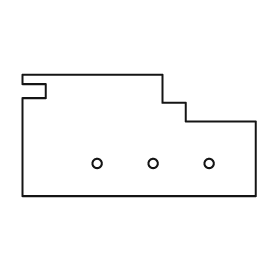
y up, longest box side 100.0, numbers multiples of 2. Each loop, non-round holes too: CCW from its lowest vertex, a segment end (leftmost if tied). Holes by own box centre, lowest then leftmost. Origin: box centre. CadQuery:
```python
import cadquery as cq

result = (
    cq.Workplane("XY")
    .moveTo(-50.0, -26.0)
    .lineTo(50.0, -26.0)
    .lineTo(50.0, 6.0)
    .lineTo(20.0, 6.0)
    .lineTo(20.0, 14.0)
    .lineTo(10.0, 14.0)
    .lineTo(10.0, 26.0)
    .lineTo(-50.0, 26.0)
    .lineTo(-50.0, 22.0)
    .lineTo(-40.0, 22.0)
    .lineTo(-40.0, 16.0)
    .lineTo(-50.0, 16.0)
    .close()
    .moveTo(-18.0, -12.0)
    .circle(2.0)
    .moveTo(6.0, -12.0)
    .circle(2.0)
    .moveTo(30.0, -12.0)
    .circle(2.0)
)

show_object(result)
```